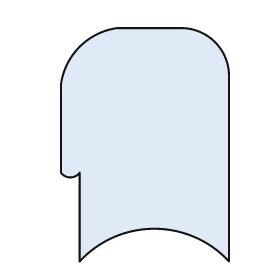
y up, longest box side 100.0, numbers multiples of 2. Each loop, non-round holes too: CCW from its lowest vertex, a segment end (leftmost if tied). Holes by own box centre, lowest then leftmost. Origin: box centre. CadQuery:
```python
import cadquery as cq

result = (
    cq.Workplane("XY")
    .moveTo(-28.0, -50.0)
    .threePointArc((4.0, -36.0), (36.0, -50.0))
    .lineTo(36.0, 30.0)
    .threePointArc((30.0, 44.0), (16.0, 50.0))
    .lineTo(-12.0, 50.0)
    .threePointArc((-28.0, 42.0), (-36.0, 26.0))
    .lineTo(-36.0, -12.0)
    .threePointArc((-32.0, -14.0), (-28.0, -12.0))
    .close()
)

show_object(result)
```